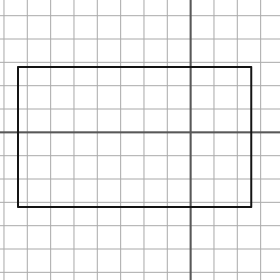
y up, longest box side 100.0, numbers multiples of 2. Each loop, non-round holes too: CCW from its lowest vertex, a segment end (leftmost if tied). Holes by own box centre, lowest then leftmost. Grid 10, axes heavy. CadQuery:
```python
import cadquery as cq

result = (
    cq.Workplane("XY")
    .moveTo(-74.0, -32.0)
    .lineTo(26.0, -32.0)
    .lineTo(26.0, 28.0)
    .lineTo(-74.0, 28.0)
    .close()
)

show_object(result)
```